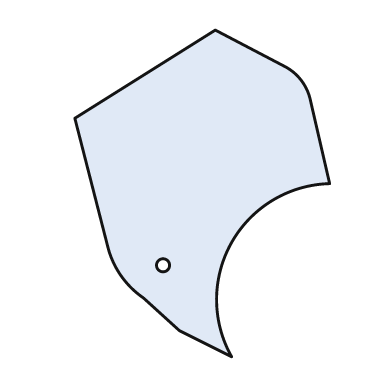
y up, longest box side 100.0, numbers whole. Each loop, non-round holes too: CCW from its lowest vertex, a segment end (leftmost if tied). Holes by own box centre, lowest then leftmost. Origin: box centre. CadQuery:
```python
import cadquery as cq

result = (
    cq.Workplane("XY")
    .moveTo(9.0, -50.0)
    .threePointArc((9.0, -15.0), (39.0, 3.0))
    .lineTo(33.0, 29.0)
    .threePointArc((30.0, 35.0), (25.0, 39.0))
    .lineTo(4.0, 50.0)
    .lineTo(-39.0, 23.0)
    .lineTo(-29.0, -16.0)
    .threePointArc((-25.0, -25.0), (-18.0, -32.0))
    .lineTo(-7.0, -42.0)
    .close()
    .moveTo(-12.0, -22.0)
    .circle(2.0)
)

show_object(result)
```